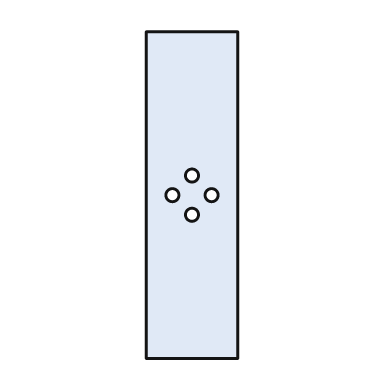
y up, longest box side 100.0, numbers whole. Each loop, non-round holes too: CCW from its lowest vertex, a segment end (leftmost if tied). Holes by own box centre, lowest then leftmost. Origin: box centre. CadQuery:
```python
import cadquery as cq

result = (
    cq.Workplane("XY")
    .moveTo(-14.0, -50.0)
    .lineTo(14.0, -50.0)
    .lineTo(14.0, 50.0)
    .lineTo(-14.0, 50.0)
    .close()
    .moveTo(0.0, -6.0)
    .circle(2.0)
    .moveTo(-6.0, 0.0)
    .circle(2.0)
    .moveTo(6.0, 0.0)
    .circle(2.0)
    .moveTo(0.0, 6.0)
    .circle(2.0)
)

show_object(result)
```